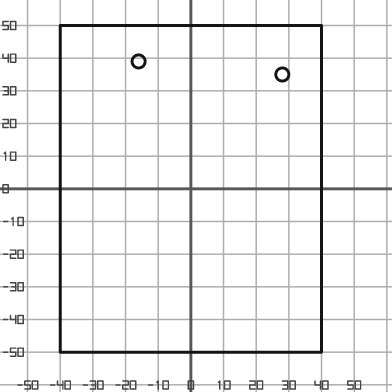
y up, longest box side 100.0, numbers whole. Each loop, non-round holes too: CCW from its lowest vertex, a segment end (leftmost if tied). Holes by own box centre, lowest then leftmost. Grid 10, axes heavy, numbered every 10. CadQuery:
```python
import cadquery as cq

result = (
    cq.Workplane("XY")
    .moveTo(-40.0, -50.0)
    .lineTo(40.0, -50.0)
    .lineTo(40.0, 50.0)
    .lineTo(-40.0, 50.0)
    .close()
    .moveTo(28.0, 35.0)
    .circle(2.0)
    .moveTo(-16.0, 39.0)
    .circle(2.0)
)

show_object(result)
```